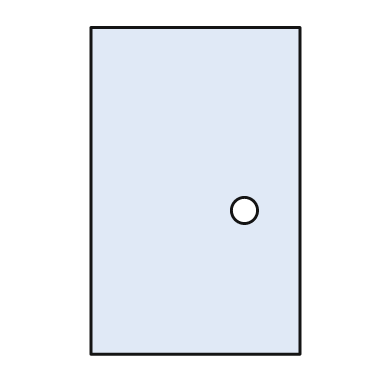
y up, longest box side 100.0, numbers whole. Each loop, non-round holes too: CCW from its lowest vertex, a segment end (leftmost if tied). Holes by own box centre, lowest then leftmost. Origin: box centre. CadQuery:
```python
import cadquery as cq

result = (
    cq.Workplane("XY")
    .moveTo(-32.0, -50.0)
    .lineTo(32.0, -50.0)
    .lineTo(32.0, 50.0)
    .lineTo(-32.0, 50.0)
    .close()
    .moveTo(15.0, -6.0)
    .circle(4.0)
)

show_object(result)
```